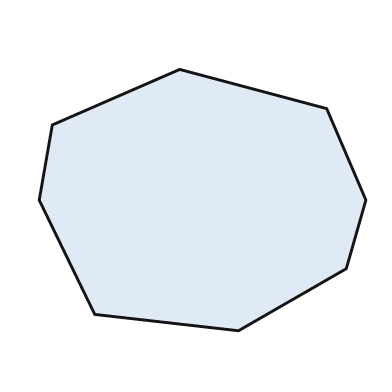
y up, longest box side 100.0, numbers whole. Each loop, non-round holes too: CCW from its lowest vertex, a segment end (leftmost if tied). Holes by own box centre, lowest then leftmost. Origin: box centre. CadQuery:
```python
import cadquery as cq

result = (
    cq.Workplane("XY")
    .moveTo(11.0, -40.0)
    .lineTo(44.0, -21.0)
    .lineTo(50.0, 0.0)
    .lineTo(38.0, 28.0)
    .lineTo(-7.0, 40.0)
    .lineTo(-46.0, 23.0)
    .lineTo(-50.0, 0.0)
    .lineTo(-33.0, -35.0)
    .close()
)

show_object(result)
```